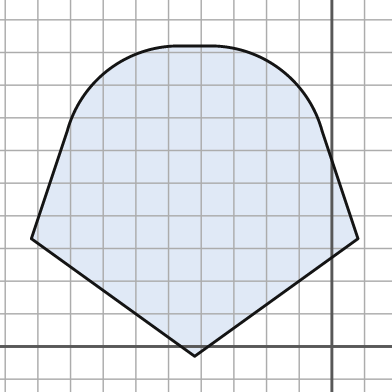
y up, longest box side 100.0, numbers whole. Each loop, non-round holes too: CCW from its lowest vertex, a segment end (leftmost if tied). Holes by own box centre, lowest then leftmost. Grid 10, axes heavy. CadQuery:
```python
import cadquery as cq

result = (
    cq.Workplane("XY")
    .moveTo(-42.0, -3.0)
    .lineTo(8.0, 33.0)
    .lineTo(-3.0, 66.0)
    .threePointArc((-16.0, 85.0), (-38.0, 92.0))
    .lineTo(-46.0, 92.0)
    .threePointArc((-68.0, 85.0), (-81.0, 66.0))
    .lineTo(-92.0, 33.0)
    .close()
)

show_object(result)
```